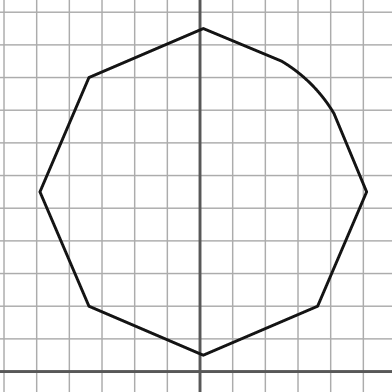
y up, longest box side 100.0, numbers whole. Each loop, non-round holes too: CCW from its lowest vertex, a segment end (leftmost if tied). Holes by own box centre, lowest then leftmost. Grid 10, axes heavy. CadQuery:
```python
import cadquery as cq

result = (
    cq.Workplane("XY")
    .moveTo(1.0, 5.0)
    .lineTo(36.0, 20.0)
    .lineTo(51.0, 55.0)
    .lineTo(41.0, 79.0)
    .threePointArc((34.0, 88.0), (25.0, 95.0))
    .lineTo(1.0, 105.0)
    .lineTo(-34.0, 90.0)
    .lineTo(-49.0, 55.0)
    .lineTo(-34.0, 20.0)
    .close()
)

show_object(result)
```